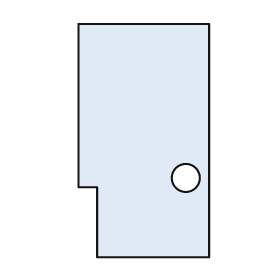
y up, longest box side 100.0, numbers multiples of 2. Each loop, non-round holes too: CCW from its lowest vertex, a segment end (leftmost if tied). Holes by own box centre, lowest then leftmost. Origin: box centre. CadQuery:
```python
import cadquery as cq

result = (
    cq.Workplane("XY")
    .moveTo(-20.0, -50.0)
    .lineTo(28.0, -50.0)
    .lineTo(28.0, 50.0)
    .lineTo(-28.0, 50.0)
    .lineTo(-28.0, -20.0)
    .lineTo(-20.0, -20.0)
    .close()
    .moveTo(18.0, -16.0)
    .circle(6.0)
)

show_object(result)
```